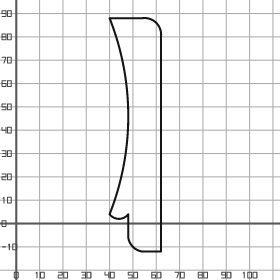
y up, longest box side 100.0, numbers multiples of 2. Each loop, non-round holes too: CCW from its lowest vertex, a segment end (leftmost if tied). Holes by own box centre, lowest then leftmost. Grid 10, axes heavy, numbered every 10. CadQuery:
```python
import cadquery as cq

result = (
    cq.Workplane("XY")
    .moveTo(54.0, -12.0)
    .lineTo(62.0, -12.0)
    .lineTo(62.0, 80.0)
    .threePointArc((60.0, 86.0), (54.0, 88.0))
    .lineTo(40.0, 88.0)
    .threePointArc((48.0, 46.0), (40.0, 4.0))
    .threePointArc((44.0, 2.0), (48.0, 4.0))
    .lineTo(48.0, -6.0)
    .threePointArc((50.0, -10.0), (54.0, -12.0))
    .close()
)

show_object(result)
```